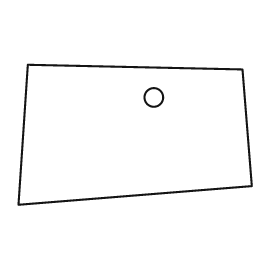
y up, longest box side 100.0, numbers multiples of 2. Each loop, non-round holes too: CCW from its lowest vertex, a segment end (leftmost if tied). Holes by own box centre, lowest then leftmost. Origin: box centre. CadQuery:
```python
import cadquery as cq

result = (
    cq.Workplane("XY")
    .moveTo(-50.0, -30.0)
    .lineTo(50.0, -22.0)
    .lineTo(46.0, 28.0)
    .lineTo(-46.0, 30.0)
    .close()
    .moveTo(8.0, 16.0)
    .circle(4.0)
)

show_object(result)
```